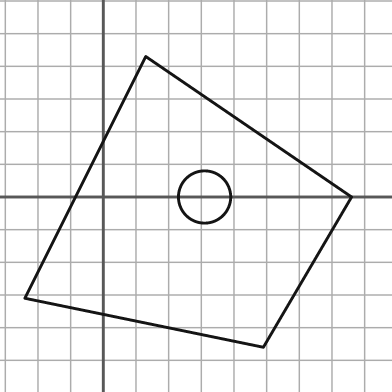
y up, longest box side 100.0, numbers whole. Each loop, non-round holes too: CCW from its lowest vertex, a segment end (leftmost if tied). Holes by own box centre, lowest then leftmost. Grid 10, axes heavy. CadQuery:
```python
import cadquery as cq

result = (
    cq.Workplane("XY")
    .moveTo(49.0, -46.0)
    .lineTo(76.0, 0.0)
    .lineTo(13.0, 43.0)
    .lineTo(-24.0, -31.0)
    .close()
    .moveTo(31.0, 0.0)
    .circle(8.0)
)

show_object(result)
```